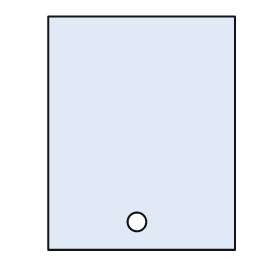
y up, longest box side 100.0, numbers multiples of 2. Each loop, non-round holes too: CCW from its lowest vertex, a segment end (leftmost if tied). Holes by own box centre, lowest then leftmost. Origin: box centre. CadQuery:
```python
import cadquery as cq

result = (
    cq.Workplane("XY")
    .moveTo(-40.0, -50.0)
    .lineTo(40.0, -50.0)
    .lineTo(40.0, 50.0)
    .lineTo(-40.0, 50.0)
    .close()
    .moveTo(-2.0, -38.0)
    .circle(4.0)
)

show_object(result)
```